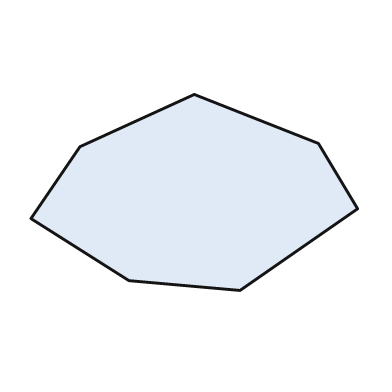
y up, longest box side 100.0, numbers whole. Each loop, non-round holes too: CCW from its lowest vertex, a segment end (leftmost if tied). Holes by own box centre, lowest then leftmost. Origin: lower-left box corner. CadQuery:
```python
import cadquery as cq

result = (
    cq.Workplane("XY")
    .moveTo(64.0, 0.0)
    .lineTo(100.0, 25.0)
    .lineTo(88.0, 45.0)
    .lineTo(50.0, 60.0)
    .lineTo(15.0, 44.0)
    .lineTo(0.0, 22.0)
    .lineTo(30.0, 3.0)
    .close()
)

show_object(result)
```